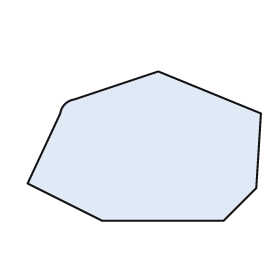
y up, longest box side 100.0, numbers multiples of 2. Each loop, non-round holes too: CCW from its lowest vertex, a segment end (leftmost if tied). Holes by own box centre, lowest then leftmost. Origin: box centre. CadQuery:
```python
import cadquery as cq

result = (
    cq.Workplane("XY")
    .moveTo(-18.0, -32.0)
    .lineTo(34.0, -32.0)
    .lineTo(48.0, -18.0)
    .lineTo(50.0, 14.0)
    .lineTo(6.0, 32.0)
    .lineTo(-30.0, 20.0)
    .threePointArc((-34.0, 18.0), (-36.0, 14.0))
    .lineTo(-50.0, -16.0)
    .close()
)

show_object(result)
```